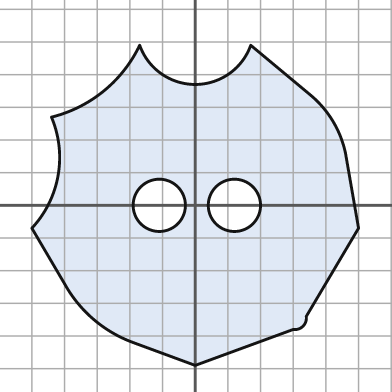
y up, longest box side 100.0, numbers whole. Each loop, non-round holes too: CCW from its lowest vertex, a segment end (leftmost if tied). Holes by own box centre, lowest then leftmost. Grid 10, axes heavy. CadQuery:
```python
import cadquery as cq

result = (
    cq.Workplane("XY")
    .moveTo(0.0, -49.0)
    .lineTo(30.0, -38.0)
    .threePointArc((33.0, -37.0), (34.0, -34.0))
    .lineTo(50.0, -7.0)
    .lineTo(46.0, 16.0)
    .threePointArc((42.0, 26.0), (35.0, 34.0))
    .lineTo(17.0, 49.0)
    .threePointArc((0.0, 37.0), (-17.0, 49.0))
    .threePointArc((-28.0, 35.0), (-44.0, 27.0))
    .threePointArc((-42.0, 9.0), (-50.0, -7.0))
    .lineTo(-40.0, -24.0)
    .threePointArc((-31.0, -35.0), (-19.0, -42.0))
    .close()
    .moveTo(-11.0, 0.0)
    .circle(8.0)
    .moveTo(12.0, 0.0)
    .circle(8.0)
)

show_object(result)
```